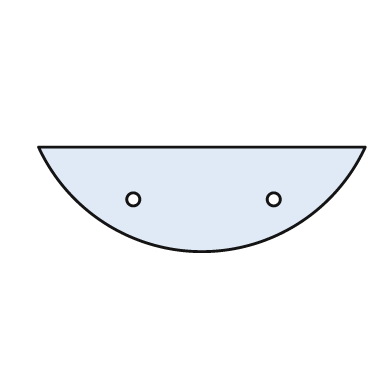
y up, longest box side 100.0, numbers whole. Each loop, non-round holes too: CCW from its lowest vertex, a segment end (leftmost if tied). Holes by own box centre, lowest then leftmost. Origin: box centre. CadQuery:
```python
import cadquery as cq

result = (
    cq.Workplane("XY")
    .moveTo(-50.0, 16.0)
    .threePointArc((0.0, -16.0), (50.0, 16.0))
    .close()
    .moveTo(-21.0, 0.0)
    .circle(2.0)
    .moveTo(22.0, 0.0)
    .circle(2.0)
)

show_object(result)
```